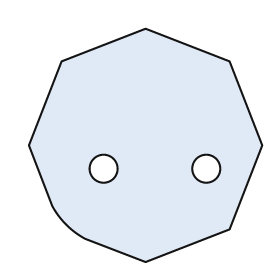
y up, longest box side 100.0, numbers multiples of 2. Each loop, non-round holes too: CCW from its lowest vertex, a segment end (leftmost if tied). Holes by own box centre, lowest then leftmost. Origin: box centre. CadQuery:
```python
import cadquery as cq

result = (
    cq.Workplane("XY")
    .moveTo(0.0, -50.0)
    .lineTo(36.0, -36.0)
    .lineTo(50.0, 0.0)
    .lineTo(36.0, 36.0)
    .lineTo(0.0, 50.0)
    .lineTo(-36.0, 36.0)
    .lineTo(-50.0, 0.0)
    .lineTo(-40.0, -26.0)
    .threePointArc((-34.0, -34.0), (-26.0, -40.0))
    .close()
    .moveTo(-18.0, -10.0)
    .circle(6.0)
    .moveTo(26.0, -10.0)
    .circle(6.0)
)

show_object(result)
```